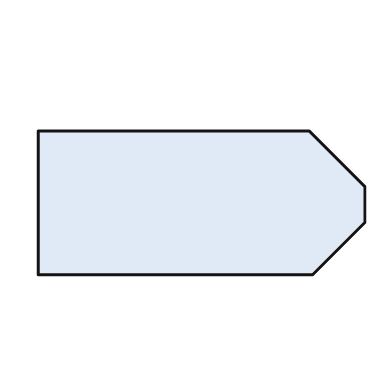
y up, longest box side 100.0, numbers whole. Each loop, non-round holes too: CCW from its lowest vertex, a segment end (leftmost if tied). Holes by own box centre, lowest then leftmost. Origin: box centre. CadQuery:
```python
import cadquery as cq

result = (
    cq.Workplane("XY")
    .moveTo(-50.0, -22.0)
    .lineTo(34.0, -22.0)
    .lineTo(50.0, -6.0)
    .lineTo(50.0, 5.0)
    .lineTo(33.0, 22.0)
    .lineTo(-50.0, 22.0)
    .close()
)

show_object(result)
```